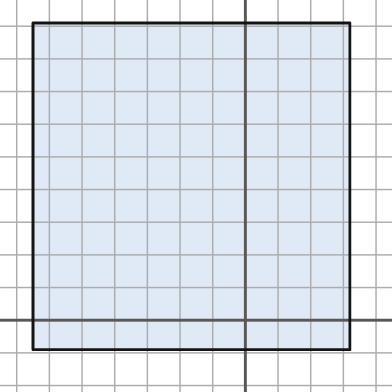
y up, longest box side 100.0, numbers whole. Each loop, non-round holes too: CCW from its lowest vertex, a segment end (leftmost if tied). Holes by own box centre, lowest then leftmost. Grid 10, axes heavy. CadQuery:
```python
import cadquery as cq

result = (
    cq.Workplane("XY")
    .moveTo(-65.0, -9.0)
    .lineTo(32.0, -9.0)
    .lineTo(32.0, 91.0)
    .lineTo(-65.0, 91.0)
    .close()
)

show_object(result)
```